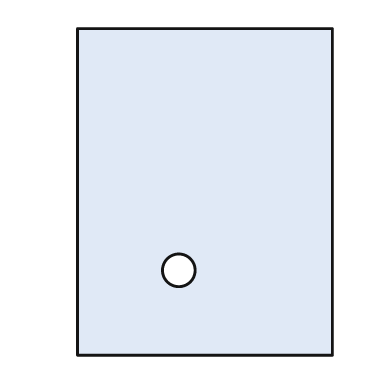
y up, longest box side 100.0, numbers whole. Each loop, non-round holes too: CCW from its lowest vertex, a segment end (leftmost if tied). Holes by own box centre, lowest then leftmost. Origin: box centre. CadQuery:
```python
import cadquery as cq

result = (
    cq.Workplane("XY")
    .moveTo(-39.0, -50.0)
    .lineTo(39.0, -50.0)
    .lineTo(39.0, 50.0)
    .lineTo(-39.0, 50.0)
    .close()
    .moveTo(-8.0, -24.0)
    .circle(5.0)
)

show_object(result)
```